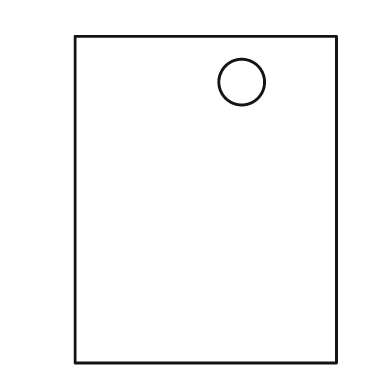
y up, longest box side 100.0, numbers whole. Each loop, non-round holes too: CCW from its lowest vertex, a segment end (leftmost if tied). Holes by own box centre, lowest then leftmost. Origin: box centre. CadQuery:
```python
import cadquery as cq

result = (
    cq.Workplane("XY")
    .moveTo(-40.0, -50.0)
    .lineTo(40.0, -50.0)
    .lineTo(40.0, 50.0)
    .lineTo(-40.0, 50.0)
    .close()
    .moveTo(11.0, 36.0)
    .circle(7.0)
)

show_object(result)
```